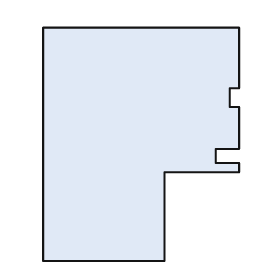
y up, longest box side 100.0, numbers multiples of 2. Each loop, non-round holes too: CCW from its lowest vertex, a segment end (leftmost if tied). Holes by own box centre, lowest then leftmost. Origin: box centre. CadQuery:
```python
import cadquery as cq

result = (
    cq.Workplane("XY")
    .moveTo(-42.0, -50.0)
    .lineTo(10.0, -50.0)
    .lineTo(10.0, -12.0)
    .lineTo(42.0, -12.0)
    .lineTo(42.0, -8.0)
    .lineTo(32.0, -8.0)
    .lineTo(32.0, -2.0)
    .lineTo(42.0, -2.0)
    .lineTo(42.0, 16.0)
    .lineTo(38.0, 16.0)
    .lineTo(38.0, 24.0)
    .lineTo(42.0, 24.0)
    .lineTo(42.0, 50.0)
    .lineTo(-42.0, 50.0)
    .close()
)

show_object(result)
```